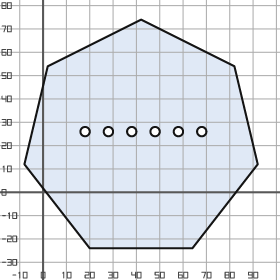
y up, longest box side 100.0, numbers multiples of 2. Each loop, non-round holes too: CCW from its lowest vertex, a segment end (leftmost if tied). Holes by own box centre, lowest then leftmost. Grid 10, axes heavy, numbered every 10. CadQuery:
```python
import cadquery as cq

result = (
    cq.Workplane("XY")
    .moveTo(20.0, -24.0)
    .lineTo(64.0, -24.0)
    .lineTo(92.0, 12.0)
    .lineTo(82.0, 54.0)
    .lineTo(42.0, 74.0)
    .lineTo(2.0, 54.0)
    .lineTo(-8.0, 12.0)
    .close()
    .moveTo(18.0, 26.0)
    .circle(2.0)
    .moveTo(28.0, 26.0)
    .circle(2.0)
    .moveTo(38.0, 26.0)
    .circle(2.0)
    .moveTo(48.0, 26.0)
    .circle(2.0)
    .moveTo(58.0, 26.0)
    .circle(2.0)
    .moveTo(68.0, 26.0)
    .circle(2.0)
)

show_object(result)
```